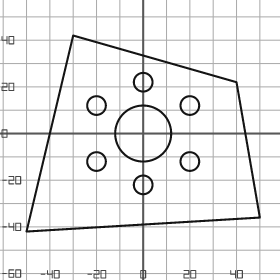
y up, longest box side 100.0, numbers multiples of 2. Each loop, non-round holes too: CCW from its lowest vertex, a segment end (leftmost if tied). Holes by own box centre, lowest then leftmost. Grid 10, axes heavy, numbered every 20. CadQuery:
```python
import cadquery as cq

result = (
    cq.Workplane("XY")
    .moveTo(-50.0, -42.0)
    .lineTo(50.0, -36.0)
    .lineTo(40.0, 22.0)
    .lineTo(-30.0, 42.0)
    .close()
    .moveTo(0.0, -22.0)
    .circle(4.0)
    .moveTo(-20.0, -12.0)
    .circle(4.0)
    .moveTo(20.0, -12.0)
    .circle(4.0)
    .moveTo(0.0, 0.0)
    .circle(12.0)
    .moveTo(-20.0, 12.0)
    .circle(4.0)
    .moveTo(20.0, 12.0)
    .circle(4.0)
    .moveTo(0.0, 22.0)
    .circle(4.0)
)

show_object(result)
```